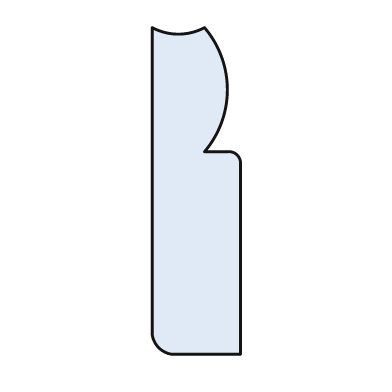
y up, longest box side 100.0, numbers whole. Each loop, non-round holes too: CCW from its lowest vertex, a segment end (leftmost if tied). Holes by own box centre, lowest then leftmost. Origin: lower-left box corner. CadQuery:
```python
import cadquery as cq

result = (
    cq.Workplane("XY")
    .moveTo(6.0, 0.0)
    .lineTo(27.0, 0.0)
    .lineTo(27.0, 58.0)
    .threePointArc((26.0, 61.0), (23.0, 62.0))
    .lineTo(16.0, 62.0)
    .threePointArc((23.0, 81.0), (16.0, 100.0))
    .threePointArc((8.0, 98.0), (0.0, 100.0))
    .lineTo(0.0, 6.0)
    .threePointArc((2.0, 2.0), (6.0, 0.0))
    .close()
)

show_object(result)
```